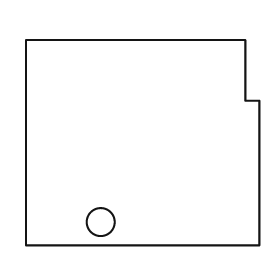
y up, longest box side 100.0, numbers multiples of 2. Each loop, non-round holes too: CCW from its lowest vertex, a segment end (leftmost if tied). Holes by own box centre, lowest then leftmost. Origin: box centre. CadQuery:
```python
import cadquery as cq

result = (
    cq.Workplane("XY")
    .moveTo(-50.0, -44.0)
    .lineTo(50.0, -44.0)
    .lineTo(50.0, 18.0)
    .lineTo(44.0, 18.0)
    .lineTo(44.0, 44.0)
    .lineTo(-50.0, 44.0)
    .close()
    .moveTo(-18.0, -34.0)
    .circle(6.0)
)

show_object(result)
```